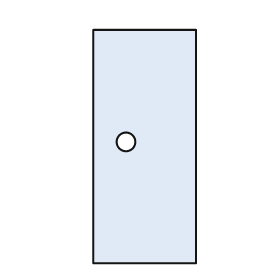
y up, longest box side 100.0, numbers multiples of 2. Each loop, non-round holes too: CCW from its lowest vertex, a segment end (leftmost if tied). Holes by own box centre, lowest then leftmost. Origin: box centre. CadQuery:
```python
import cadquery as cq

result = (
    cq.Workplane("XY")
    .moveTo(-22.0, -50.0)
    .lineTo(22.0, -50.0)
    .lineTo(22.0, 50.0)
    .lineTo(-22.0, 50.0)
    .close()
    .moveTo(-8.0, 2.0)
    .circle(4.0)
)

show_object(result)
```